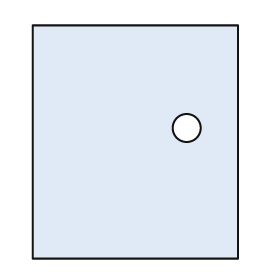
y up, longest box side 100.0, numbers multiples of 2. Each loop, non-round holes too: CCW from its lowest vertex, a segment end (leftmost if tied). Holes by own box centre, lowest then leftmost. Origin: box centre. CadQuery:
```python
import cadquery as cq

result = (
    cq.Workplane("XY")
    .moveTo(-44.0, -50.0)
    .lineTo(44.0, -50.0)
    .lineTo(44.0, 50.0)
    .lineTo(-44.0, 50.0)
    .close()
    .moveTo(22.0, 6.0)
    .circle(6.0)
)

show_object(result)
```